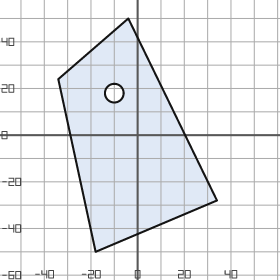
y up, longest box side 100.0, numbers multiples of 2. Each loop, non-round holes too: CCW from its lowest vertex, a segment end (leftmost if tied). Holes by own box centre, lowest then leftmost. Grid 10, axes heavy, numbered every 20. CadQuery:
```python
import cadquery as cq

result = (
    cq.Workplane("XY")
    .moveTo(-18.0, -50.0)
    .lineTo(34.0, -28.0)
    .lineTo(-4.0, 50.0)
    .lineTo(-34.0, 24.0)
    .close()
    .moveTo(-10.0, 18.0)
    .circle(4.0)
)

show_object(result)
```